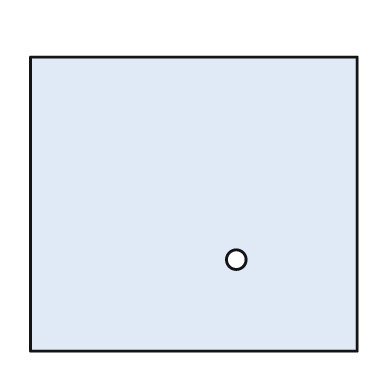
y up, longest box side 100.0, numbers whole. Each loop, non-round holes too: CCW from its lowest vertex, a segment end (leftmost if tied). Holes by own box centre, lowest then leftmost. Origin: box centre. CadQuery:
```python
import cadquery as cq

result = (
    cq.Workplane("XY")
    .moveTo(-50.0, -45.0)
    .lineTo(50.0, -45.0)
    .lineTo(50.0, 45.0)
    .lineTo(-50.0, 45.0)
    .close()
    .moveTo(13.0, -17.0)
    .circle(3.0)
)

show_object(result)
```